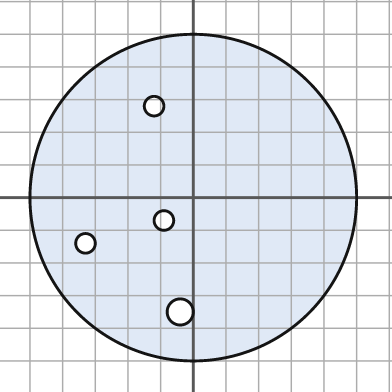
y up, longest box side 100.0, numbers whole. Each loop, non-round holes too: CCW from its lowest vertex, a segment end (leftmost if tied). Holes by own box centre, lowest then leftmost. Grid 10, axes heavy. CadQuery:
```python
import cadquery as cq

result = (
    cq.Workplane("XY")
    .moveTo(0.0, 0.0)
    .circle(50.0)
    .moveTo(-4.0, -35.0)
    .circle(4.0)
    .moveTo(-33.0, -14.0)
    .circle(3.0)
    .moveTo(-9.0, -7.0)
    .circle(3.0)
    .moveTo(-12.0, 28.0)
    .circle(3.0)
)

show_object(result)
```